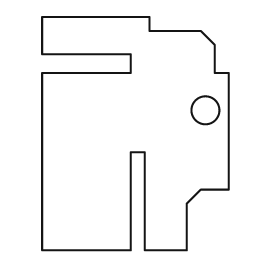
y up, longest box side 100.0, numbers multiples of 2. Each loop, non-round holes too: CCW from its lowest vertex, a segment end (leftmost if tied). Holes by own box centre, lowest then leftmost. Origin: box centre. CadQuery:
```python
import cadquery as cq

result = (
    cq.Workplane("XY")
    .moveTo(-40.0, -50.0)
    .lineTo(-2.0, -50.0)
    .lineTo(-2.0, -8.0)
    .lineTo(4.0, -8.0)
    .lineTo(4.0, -50.0)
    .lineTo(22.0, -50.0)
    .lineTo(22.0, -30.0)
    .lineTo(28.0, -24.0)
    .lineTo(40.0, -24.0)
    .lineTo(40.0, 26.0)
    .lineTo(34.0, 26.0)
    .lineTo(34.0, 38.0)
    .lineTo(28.0, 44.0)
    .lineTo(6.0, 44.0)
    .lineTo(6.0, 50.0)
    .lineTo(-40.0, 50.0)
    .lineTo(-40.0, 34.0)
    .lineTo(-2.0, 34.0)
    .lineTo(-2.0, 26.0)
    .lineTo(-40.0, 26.0)
    .close()
    .moveTo(30.0, 10.0)
    .circle(6.0)
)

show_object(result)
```